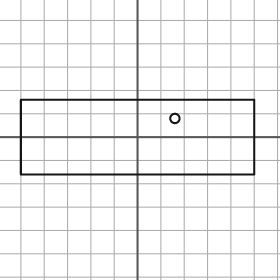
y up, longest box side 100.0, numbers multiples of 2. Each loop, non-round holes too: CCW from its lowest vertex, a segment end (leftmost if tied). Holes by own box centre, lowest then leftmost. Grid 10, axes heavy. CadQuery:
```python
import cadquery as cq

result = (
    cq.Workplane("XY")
    .moveTo(-50.0, -16.0)
    .lineTo(50.0, -16.0)
    .lineTo(50.0, 16.0)
    .lineTo(-50.0, 16.0)
    .close()
    .moveTo(16.0, 8.0)
    .circle(2.0)
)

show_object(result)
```